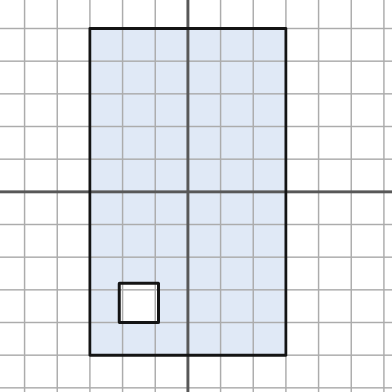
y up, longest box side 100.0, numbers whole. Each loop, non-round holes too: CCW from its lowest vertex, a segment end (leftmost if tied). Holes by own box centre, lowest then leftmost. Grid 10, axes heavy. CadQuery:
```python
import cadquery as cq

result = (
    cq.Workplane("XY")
    .moveTo(-30.0, -50.0)
    .lineTo(30.0, -50.0)
    .lineTo(30.0, 50.0)
    .lineTo(-30.0, 50.0)
    .close()
    .moveTo(-21.0, -40.0)
    .lineTo(-9.0, -40.0)
    .lineTo(-9.0, -28.0)
    .lineTo(-21.0, -28.0)
    .close()
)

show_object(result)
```